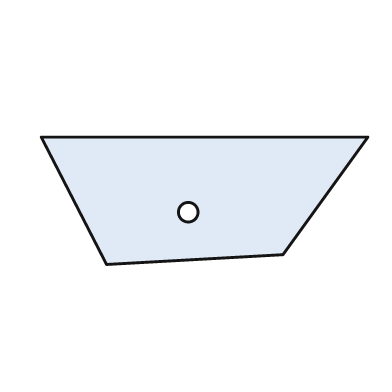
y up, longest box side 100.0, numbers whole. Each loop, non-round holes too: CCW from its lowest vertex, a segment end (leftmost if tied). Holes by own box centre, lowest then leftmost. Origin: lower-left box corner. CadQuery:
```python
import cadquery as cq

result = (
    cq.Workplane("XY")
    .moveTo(20.0, 0.0)
    .lineTo(74.0, 3.0)
    .lineTo(100.0, 39.0)
    .lineTo(0.0, 39.0)
    .close()
    .moveTo(45.0, 16.0)
    .circle(3.0)
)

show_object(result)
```